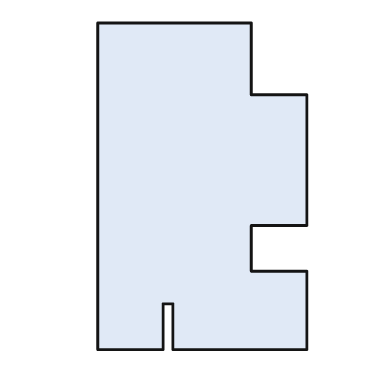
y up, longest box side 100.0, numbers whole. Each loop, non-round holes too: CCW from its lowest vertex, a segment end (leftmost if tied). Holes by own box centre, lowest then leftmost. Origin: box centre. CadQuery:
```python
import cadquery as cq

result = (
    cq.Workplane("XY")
    .moveTo(-32.0, -50.0)
    .lineTo(-12.0, -50.0)
    .lineTo(-12.0, -36.0)
    .lineTo(-9.0, -36.0)
    .lineTo(-9.0, -50.0)
    .lineTo(32.0, -50.0)
    .lineTo(32.0, -26.0)
    .lineTo(15.0, -26.0)
    .lineTo(15.0, -12.0)
    .lineTo(32.0, -12.0)
    .lineTo(32.0, 28.0)
    .lineTo(15.0, 28.0)
    .lineTo(15.0, 50.0)
    .lineTo(-32.0, 50.0)
    .close()
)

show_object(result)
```